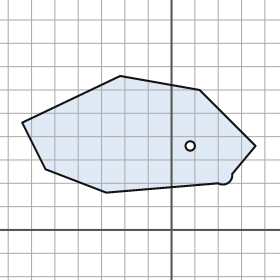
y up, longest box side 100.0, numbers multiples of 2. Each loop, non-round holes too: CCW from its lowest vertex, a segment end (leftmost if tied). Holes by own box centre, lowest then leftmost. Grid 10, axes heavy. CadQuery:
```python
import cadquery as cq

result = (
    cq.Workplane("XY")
    .moveTo(-28.0, 16.0)
    .lineTo(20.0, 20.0)
    .threePointArc((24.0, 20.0), (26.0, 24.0))
    .lineTo(36.0, 36.0)
    .lineTo(12.0, 60.0)
    .lineTo(-22.0, 66.0)
    .lineTo(-64.0, 46.0)
    .lineTo(-54.0, 26.0)
    .close()
    .moveTo(8.0, 36.0)
    .circle(2.0)
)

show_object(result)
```